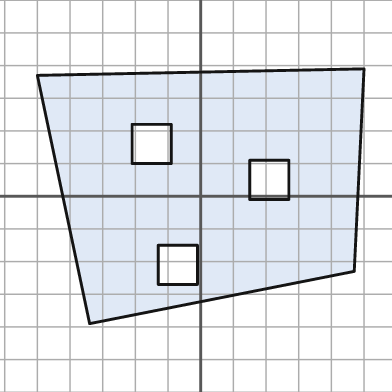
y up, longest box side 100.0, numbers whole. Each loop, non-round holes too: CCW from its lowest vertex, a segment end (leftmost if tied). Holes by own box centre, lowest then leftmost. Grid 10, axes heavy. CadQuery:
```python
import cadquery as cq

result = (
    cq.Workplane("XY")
    .moveTo(-34.0, -39.0)
    .lineTo(47.0, -23.0)
    .lineTo(50.0, 39.0)
    .lineTo(-50.0, 37.0)
    .close()
    .moveTo(-13.0, -27.0)
    .lineTo(-1.0, -27.0)
    .lineTo(-1.0, -15.0)
    .lineTo(-13.0, -15.0)
    .close()
    .moveTo(15.0, -1.0)
    .lineTo(27.0, -1.0)
    .lineTo(27.0, 11.0)
    .lineTo(15.0, 11.0)
    .close()
    .moveTo(-21.0, 10.0)
    .lineTo(-9.0, 10.0)
    .lineTo(-9.0, 22.0)
    .lineTo(-21.0, 22.0)
    .close()
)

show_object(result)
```